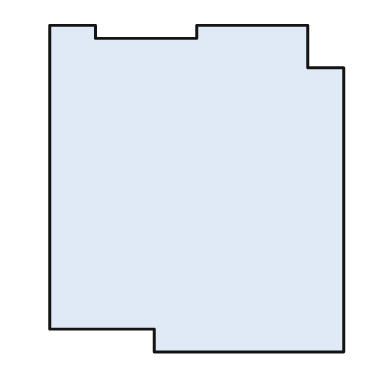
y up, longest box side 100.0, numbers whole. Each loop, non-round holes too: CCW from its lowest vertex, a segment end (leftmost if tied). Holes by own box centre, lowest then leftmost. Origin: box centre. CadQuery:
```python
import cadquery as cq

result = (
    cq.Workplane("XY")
    .moveTo(-13.0, -50.0)
    .lineTo(45.0, -50.0)
    .lineTo(45.0, 37.0)
    .lineTo(34.0, 37.0)
    .lineTo(34.0, 50.0)
    .lineTo(0.0, 50.0)
    .lineTo(0.0, 46.0)
    .lineTo(-31.0, 46.0)
    .lineTo(-31.0, 50.0)
    .lineTo(-45.0, 50.0)
    .lineTo(-45.0, -43.0)
    .lineTo(-13.0, -43.0)
    .close()
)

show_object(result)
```